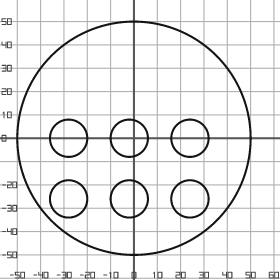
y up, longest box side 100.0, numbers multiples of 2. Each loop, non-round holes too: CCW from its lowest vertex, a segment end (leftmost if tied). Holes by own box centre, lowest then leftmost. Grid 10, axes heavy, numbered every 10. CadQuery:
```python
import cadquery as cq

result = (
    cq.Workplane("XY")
    .moveTo(0.0, 0.0)
    .circle(50.0)
    .moveTo(-28.0, -26.0)
    .circle(8.0)
    .moveTo(-2.0, -26.0)
    .circle(8.0)
    .moveTo(24.0, -26.0)
    .circle(8.0)
    .moveTo(-28.0, 0.0)
    .circle(8.0)
    .moveTo(-2.0, 0.0)
    .circle(8.0)
    .moveTo(24.0, 0.0)
    .circle(8.0)
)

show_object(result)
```